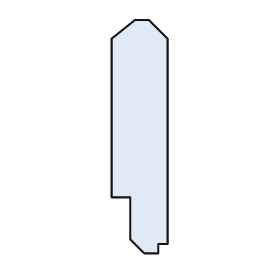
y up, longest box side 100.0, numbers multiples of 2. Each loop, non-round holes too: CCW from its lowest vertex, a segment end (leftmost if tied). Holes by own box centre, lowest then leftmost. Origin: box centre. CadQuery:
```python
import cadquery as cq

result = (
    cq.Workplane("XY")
    .moveTo(2.0, -50.0)
    .lineTo(8.0, -50.0)
    .lineTo(8.0, -46.0)
    .lineTo(12.0, -46.0)
    .lineTo(12.0, 42.0)
    .lineTo(4.0, 50.0)
    .lineTo(-2.0, 50.0)
    .lineTo(-12.0, 42.0)
    .lineTo(-12.0, -26.0)
    .lineTo(-4.0, -26.0)
    .lineTo(-4.0, -44.0)
    .close()
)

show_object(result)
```